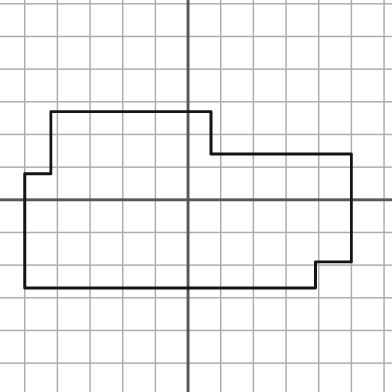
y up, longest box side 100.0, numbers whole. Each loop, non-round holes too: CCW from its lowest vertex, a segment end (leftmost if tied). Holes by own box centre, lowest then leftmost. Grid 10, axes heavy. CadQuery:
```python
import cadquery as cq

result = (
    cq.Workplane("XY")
    .moveTo(-50.0, -27.0)
    .lineTo(39.0, -27.0)
    .lineTo(39.0, -19.0)
    .lineTo(50.0, -19.0)
    .lineTo(50.0, 14.0)
    .lineTo(7.0, 14.0)
    .lineTo(7.0, 27.0)
    .lineTo(-42.0, 27.0)
    .lineTo(-42.0, 8.0)
    .lineTo(-50.0, 8.0)
    .close()
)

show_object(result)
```